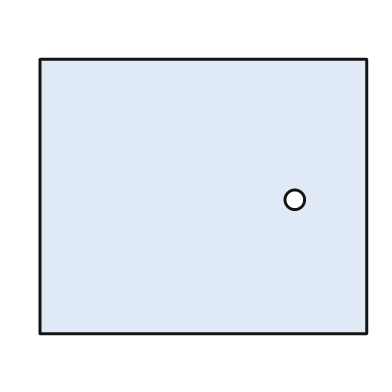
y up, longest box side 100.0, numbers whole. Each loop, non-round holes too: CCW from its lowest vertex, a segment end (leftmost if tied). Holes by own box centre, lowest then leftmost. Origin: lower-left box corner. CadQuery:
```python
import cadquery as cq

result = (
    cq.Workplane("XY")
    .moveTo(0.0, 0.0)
    .lineTo(100.0, 0.0)
    .lineTo(100.0, 84.0)
    .lineTo(0.0, 84.0)
    .close()
    .moveTo(78.0, 41.0)
    .circle(3.0)
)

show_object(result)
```